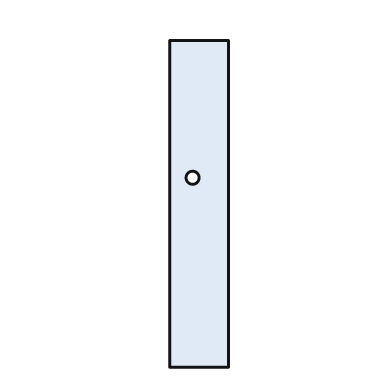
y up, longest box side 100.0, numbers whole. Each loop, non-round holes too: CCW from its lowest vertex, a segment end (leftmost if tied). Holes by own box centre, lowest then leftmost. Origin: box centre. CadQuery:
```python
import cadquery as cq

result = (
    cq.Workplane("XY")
    .moveTo(-9.0, -50.0)
    .lineTo(9.0, -50.0)
    .lineTo(9.0, 50.0)
    .lineTo(-9.0, 50.0)
    .close()
    .moveTo(-2.0, 8.0)
    .circle(2.0)
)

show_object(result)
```